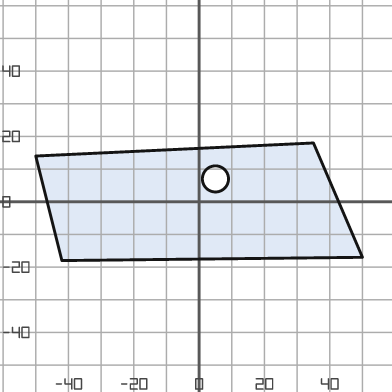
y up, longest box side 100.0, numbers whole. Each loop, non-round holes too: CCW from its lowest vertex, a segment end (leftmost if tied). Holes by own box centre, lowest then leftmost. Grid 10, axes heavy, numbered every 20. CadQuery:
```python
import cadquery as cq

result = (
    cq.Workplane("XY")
    .moveTo(-42.0, -18.0)
    .lineTo(50.0, -17.0)
    .lineTo(35.0, 18.0)
    .lineTo(-50.0, 14.0)
    .close()
    .moveTo(5.0, 7.0)
    .circle(4.0)
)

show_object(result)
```